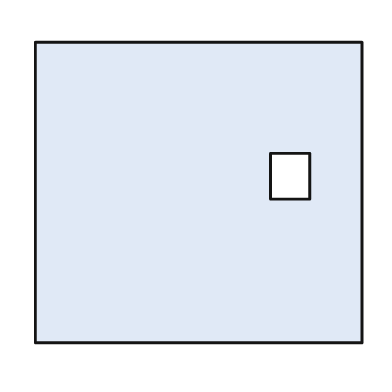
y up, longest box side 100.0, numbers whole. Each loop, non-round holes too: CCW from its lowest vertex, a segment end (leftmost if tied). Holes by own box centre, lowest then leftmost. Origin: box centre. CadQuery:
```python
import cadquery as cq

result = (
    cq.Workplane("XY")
    .moveTo(-50.0, -46.0)
    .lineTo(50.0, -46.0)
    .lineTo(50.0, 46.0)
    .lineTo(-50.0, 46.0)
    .close()
    .moveTo(22.0, -2.0)
    .lineTo(34.0, -2.0)
    .lineTo(34.0, 12.0)
    .lineTo(22.0, 12.0)
    .close()
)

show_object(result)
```